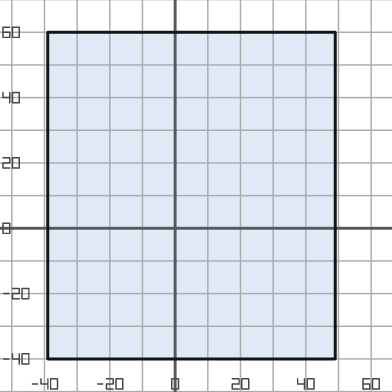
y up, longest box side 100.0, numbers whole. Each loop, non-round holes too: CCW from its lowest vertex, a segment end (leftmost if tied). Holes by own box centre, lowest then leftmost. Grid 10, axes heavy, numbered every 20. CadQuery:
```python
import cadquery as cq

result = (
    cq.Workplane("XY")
    .moveTo(-39.0, -40.0)
    .lineTo(49.0, -40.0)
    .lineTo(49.0, 60.0)
    .lineTo(-39.0, 60.0)
    .close()
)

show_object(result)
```